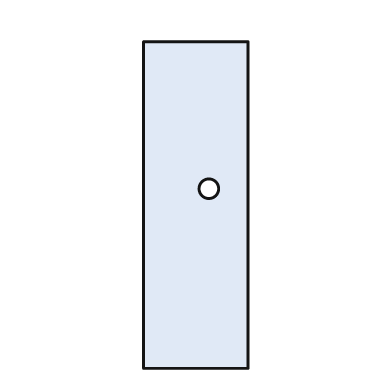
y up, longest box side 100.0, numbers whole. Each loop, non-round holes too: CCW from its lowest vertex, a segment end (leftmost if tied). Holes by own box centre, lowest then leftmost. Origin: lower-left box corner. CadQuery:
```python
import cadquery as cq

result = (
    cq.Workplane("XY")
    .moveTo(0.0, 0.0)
    .lineTo(32.0, 0.0)
    .lineTo(32.0, 100.0)
    .lineTo(0.0, 100.0)
    .close()
    .moveTo(20.0, 55.0)
    .circle(3.0)
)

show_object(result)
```